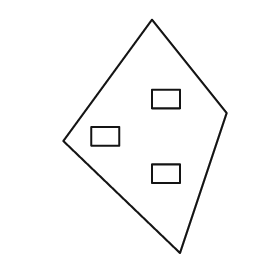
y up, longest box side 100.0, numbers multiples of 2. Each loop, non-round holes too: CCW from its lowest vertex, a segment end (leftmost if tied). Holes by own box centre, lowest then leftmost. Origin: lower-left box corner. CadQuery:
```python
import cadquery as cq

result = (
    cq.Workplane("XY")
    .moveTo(50.0, 0.0)
    .lineTo(70.0, 60.0)
    .lineTo(38.0, 100.0)
    .lineTo(0.0, 48.0)
    .close()
    .moveTo(38.0, 30.0)
    .lineTo(50.0, 30.0)
    .lineTo(50.0, 38.0)
    .lineTo(38.0, 38.0)
    .close()
    .moveTo(12.0, 46.0)
    .lineTo(24.0, 46.0)
    .lineTo(24.0, 54.0)
    .lineTo(12.0, 54.0)
    .close()
    .moveTo(38.0, 62.0)
    .lineTo(50.0, 62.0)
    .lineTo(50.0, 70.0)
    .lineTo(38.0, 70.0)
    .close()
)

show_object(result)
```